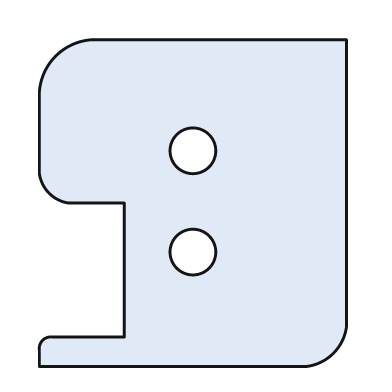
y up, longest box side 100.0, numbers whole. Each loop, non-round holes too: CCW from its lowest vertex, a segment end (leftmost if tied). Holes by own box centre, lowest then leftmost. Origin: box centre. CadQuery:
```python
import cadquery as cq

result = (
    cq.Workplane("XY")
    .moveTo(-47.0, -50.0)
    .lineTo(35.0, -50.0)
    .threePointArc((43.0, -46.0), (47.0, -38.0))
    .lineTo(47.0, 50.0)
    .lineTo(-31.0, 50.0)
    .threePointArc((-42.0, 45.0), (-47.0, 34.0))
    .lineTo(-47.0, 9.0)
    .threePointArc((-44.0, 3.0), (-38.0, 0.0))
    .lineTo(-21.0, 0.0)
    .lineTo(-21.0, -41.0)
    .lineTo(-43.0, -41.0)
    .threePointArc((-46.0, -42.0), (-47.0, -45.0))
    .close()
    .moveTo(0.0, -15.0)
    .circle(7.0)
    .moveTo(0.0, 16.0)
    .circle(7.0)
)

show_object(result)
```